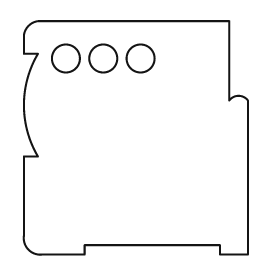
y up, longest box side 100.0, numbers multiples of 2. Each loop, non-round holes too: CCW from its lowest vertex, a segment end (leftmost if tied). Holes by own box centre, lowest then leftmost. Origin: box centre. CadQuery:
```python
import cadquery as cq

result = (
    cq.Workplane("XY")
    .moveTo(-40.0, -50.0)
    .lineTo(-22.0, -50.0)
    .lineTo(-22.0, -46.0)
    .lineTo(36.0, -46.0)
    .lineTo(36.0, -50.0)
    .lineTo(48.0, -50.0)
    .lineTo(48.0, 16.0)
    .threePointArc((44.0, 18.0), (40.0, 16.0))
    .lineTo(40.0, 50.0)
    .lineTo(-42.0, 50.0)
    .threePointArc((-46.0, 48.0), (-48.0, 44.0))
    .lineTo(-48.0, 36.0)
    .lineTo(-42.0, 36.0)
    .threePointArc((-48.0, 14.0), (-42.0, -8.0))
    .lineTo(-48.0, -8.0)
    .lineTo(-48.0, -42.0)
    .threePointArc((-46.0, -48.0), (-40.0, -50.0))
    .close()
    .moveTo(-30.0, 34.0)
    .circle(6.0)
    .moveTo(-14.0, 34.0)
    .circle(6.0)
    .moveTo(2.0, 34.0)
    .circle(6.0)
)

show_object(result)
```